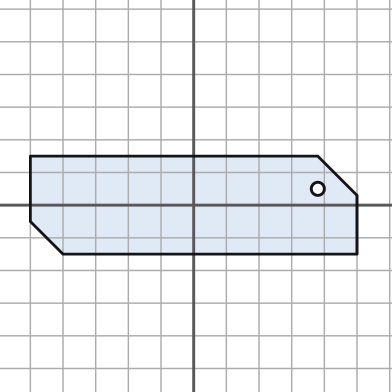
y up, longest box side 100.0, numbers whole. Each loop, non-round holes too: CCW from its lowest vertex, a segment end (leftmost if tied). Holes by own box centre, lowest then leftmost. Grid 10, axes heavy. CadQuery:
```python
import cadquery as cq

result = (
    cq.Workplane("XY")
    .moveTo(-40.0, -15.0)
    .lineTo(50.0, -15.0)
    .lineTo(50.0, 3.0)
    .lineTo(38.0, 15.0)
    .lineTo(-50.0, 15.0)
    .lineTo(-50.0, -5.0)
    .close()
    .moveTo(38.0, 5.0)
    .circle(2.0)
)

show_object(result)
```